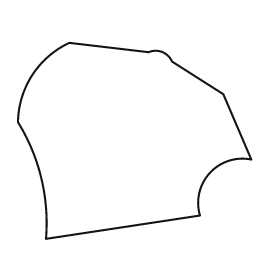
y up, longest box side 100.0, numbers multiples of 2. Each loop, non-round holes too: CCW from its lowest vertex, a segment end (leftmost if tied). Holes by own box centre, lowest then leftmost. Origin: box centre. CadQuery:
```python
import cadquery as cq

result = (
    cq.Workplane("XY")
    .moveTo(-38.0, -42.0)
    .lineTo(28.0, -32.0)
    .threePointArc((32.0, -14.0), (50.0, -8.0))
    .lineTo(38.0, 20.0)
    .lineTo(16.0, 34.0)
    .threePointArc((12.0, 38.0), (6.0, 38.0))
    .lineTo(-28.0, 42.0)
    .threePointArc((-44.0, 28.0), (-50.0, 8.0))
    .threePointArc((-40.0, -16.0), (-38.0, -42.0))
    .close()
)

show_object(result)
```